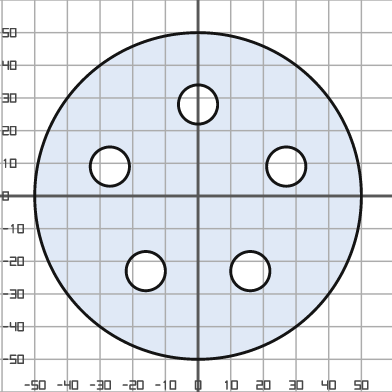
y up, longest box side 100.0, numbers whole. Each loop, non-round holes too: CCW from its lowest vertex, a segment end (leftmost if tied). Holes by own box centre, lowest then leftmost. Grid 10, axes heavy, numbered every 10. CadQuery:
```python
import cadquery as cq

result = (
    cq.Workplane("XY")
    .moveTo(0.0, 0.0)
    .circle(50.0)
    .moveTo(-16.0, -23.0)
    .circle(6.0)
    .moveTo(16.0, -23.0)
    .circle(6.0)
    .moveTo(-27.0, 9.0)
    .circle(6.0)
    .moveTo(27.0, 9.0)
    .circle(6.0)
    .moveTo(0.0, 28.0)
    .circle(6.0)
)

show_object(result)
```